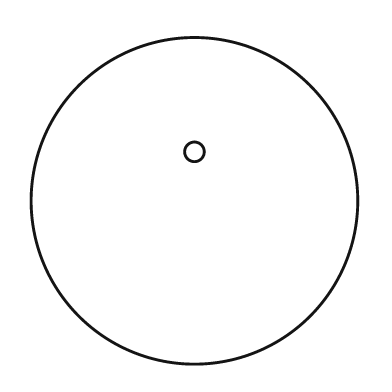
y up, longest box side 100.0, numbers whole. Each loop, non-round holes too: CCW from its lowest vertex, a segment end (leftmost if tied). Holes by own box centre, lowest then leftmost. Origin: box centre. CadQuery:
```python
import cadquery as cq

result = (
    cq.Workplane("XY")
    .moveTo(0.0, 0.0)
    .circle(50.0)
    .moveTo(0.0, 15.0)
    .circle(3.0)
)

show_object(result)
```